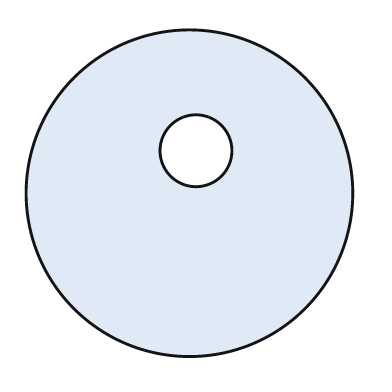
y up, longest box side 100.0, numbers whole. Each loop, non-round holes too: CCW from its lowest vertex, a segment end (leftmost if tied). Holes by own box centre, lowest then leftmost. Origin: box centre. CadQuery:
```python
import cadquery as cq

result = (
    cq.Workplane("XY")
    .moveTo(0.0, 0.0)
    .circle(50.0)
    .moveTo(2.0, 13.0)
    .circle(11.0)
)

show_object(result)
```